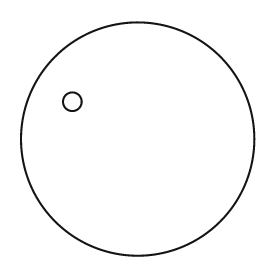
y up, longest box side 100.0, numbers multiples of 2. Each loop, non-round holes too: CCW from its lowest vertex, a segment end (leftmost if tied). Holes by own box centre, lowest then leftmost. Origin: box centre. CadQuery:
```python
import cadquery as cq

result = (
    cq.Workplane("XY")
    .moveTo(0.0, 0.0)
    .circle(50.0)
    .moveTo(-28.0, 16.0)
    .circle(4.0)
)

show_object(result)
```